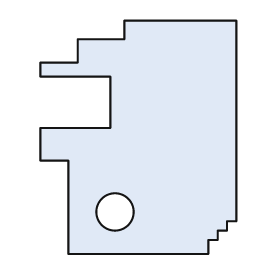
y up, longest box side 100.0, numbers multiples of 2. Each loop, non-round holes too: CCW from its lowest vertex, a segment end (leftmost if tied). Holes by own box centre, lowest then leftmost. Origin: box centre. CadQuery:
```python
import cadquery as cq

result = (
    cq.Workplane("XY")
    .moveTo(-30.0, -50.0)
    .lineTo(30.0, -50.0)
    .lineTo(30.0, -44.0)
    .lineTo(34.0, -44.0)
    .lineTo(34.0, -40.0)
    .lineTo(38.0, -40.0)
    .lineTo(38.0, -36.0)
    .lineTo(42.0, -36.0)
    .lineTo(42.0, 50.0)
    .lineTo(-6.0, 50.0)
    .lineTo(-6.0, 42.0)
    .lineTo(-26.0, 42.0)
    .lineTo(-26.0, 32.0)
    .lineTo(-42.0, 32.0)
    .lineTo(-42.0, 26.0)
    .lineTo(-12.0, 26.0)
    .lineTo(-12.0, 4.0)
    .lineTo(-42.0, 4.0)
    .lineTo(-42.0, -10.0)
    .lineTo(-30.0, -10.0)
    .close()
    .moveTo(-10.0, -32.0)
    .circle(8.0)
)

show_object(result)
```